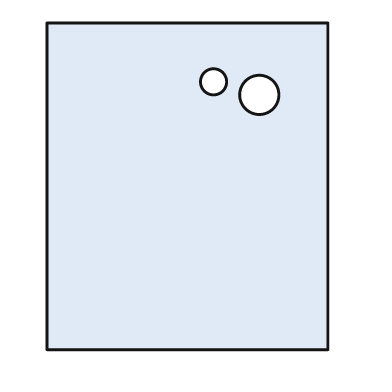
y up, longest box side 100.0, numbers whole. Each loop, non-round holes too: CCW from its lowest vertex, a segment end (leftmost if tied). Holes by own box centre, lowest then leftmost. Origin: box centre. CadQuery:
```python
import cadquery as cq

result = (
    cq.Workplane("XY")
    .moveTo(-43.0, -50.0)
    .lineTo(43.0, -50.0)
    .lineTo(43.0, 50.0)
    .lineTo(-43.0, 50.0)
    .close()
    .moveTo(22.0, 28.0)
    .circle(6.0)
    .moveTo(8.0, 32.0)
    .circle(4.0)
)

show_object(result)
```